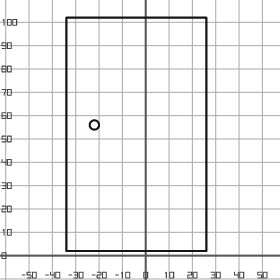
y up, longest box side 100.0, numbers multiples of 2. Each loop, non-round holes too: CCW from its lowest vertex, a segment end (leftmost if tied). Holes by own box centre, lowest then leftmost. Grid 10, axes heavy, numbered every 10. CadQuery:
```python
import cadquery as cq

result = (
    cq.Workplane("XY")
    .moveTo(-34.0, 2.0)
    .lineTo(26.0, 2.0)
    .lineTo(26.0, 102.0)
    .lineTo(-34.0, 102.0)
    .close()
    .moveTo(-22.0, 56.0)
    .circle(2.0)
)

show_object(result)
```